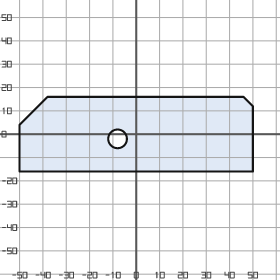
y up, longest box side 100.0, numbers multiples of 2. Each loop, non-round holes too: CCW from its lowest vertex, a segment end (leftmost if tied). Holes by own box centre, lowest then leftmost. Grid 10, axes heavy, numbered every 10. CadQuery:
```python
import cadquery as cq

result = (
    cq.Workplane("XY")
    .moveTo(-50.0, -16.0)
    .lineTo(50.0, -16.0)
    .lineTo(50.0, 12.0)
    .lineTo(46.0, 16.0)
    .lineTo(-38.0, 16.0)
    .lineTo(-50.0, 4.0)
    .close()
    .moveTo(-8.0, -2.0)
    .circle(4.0)
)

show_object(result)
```